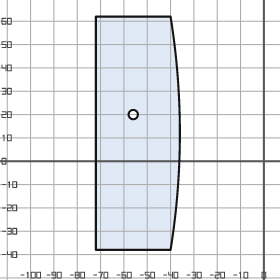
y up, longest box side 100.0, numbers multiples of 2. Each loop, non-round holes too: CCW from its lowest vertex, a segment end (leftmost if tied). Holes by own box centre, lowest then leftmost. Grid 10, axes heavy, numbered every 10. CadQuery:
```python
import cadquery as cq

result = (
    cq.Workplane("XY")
    .moveTo(-72.0, -38.0)
    .lineTo(-40.0, -38.0)
    .threePointArc((-36.0, 12.0), (-40.0, 62.0))
    .lineTo(-72.0, 62.0)
    .close()
    .moveTo(-56.0, 20.0)
    .circle(2.0)
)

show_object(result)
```